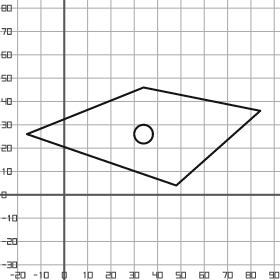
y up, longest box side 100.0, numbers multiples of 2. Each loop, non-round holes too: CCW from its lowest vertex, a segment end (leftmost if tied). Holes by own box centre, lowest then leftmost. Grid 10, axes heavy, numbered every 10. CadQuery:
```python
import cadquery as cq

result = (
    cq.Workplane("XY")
    .moveTo(48.0, 4.0)
    .lineTo(84.0, 36.0)
    .lineTo(34.0, 46.0)
    .lineTo(-16.0, 26.0)
    .close()
    .moveTo(34.0, 26.0)
    .circle(4.0)
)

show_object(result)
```